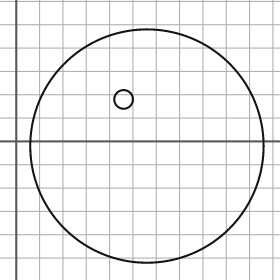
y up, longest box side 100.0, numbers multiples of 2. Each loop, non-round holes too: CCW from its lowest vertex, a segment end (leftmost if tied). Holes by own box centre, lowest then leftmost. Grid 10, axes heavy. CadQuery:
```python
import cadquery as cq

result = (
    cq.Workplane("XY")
    .moveTo(56.0, -2.0)
    .circle(50.0)
    .moveTo(46.0, 18.0)
    .circle(4.0)
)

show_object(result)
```